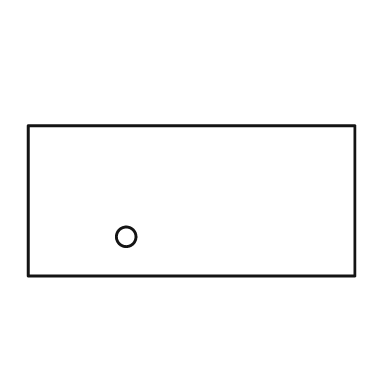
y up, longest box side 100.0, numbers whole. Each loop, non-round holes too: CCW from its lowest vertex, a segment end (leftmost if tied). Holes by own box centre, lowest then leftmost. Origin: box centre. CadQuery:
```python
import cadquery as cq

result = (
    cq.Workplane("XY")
    .moveTo(-50.0, -23.0)
    .lineTo(50.0, -23.0)
    .lineTo(50.0, 23.0)
    .lineTo(-50.0, 23.0)
    .close()
    .moveTo(-20.0, -11.0)
    .circle(3.0)
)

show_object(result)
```